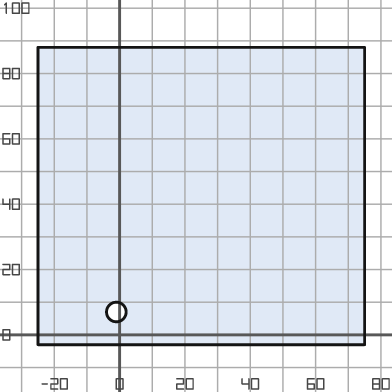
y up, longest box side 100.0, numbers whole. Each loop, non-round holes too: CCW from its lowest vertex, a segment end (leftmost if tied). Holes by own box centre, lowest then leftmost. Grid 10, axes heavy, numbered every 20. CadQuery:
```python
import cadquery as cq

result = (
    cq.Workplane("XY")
    .moveTo(-25.0, -3.0)
    .lineTo(75.0, -3.0)
    .lineTo(75.0, 88.0)
    .lineTo(-25.0, 88.0)
    .close()
    .moveTo(-1.0, 7.0)
    .circle(3.0)
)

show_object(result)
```